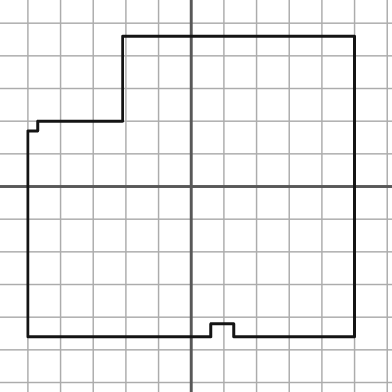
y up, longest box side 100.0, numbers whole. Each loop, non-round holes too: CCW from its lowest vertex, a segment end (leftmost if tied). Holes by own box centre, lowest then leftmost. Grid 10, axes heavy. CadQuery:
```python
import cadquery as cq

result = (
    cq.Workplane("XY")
    .moveTo(-50.0, -46.0)
    .lineTo(6.0, -46.0)
    .lineTo(6.0, -42.0)
    .lineTo(13.0, -42.0)
    .lineTo(13.0, -46.0)
    .lineTo(50.0, -46.0)
    .lineTo(50.0, 46.0)
    .lineTo(-21.0, 46.0)
    .lineTo(-21.0, 20.0)
    .lineTo(-47.0, 20.0)
    .lineTo(-47.0, 17.0)
    .lineTo(-50.0, 17.0)
    .close()
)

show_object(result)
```